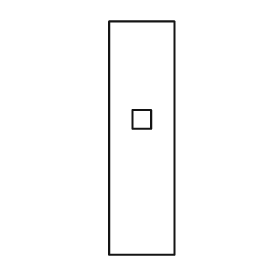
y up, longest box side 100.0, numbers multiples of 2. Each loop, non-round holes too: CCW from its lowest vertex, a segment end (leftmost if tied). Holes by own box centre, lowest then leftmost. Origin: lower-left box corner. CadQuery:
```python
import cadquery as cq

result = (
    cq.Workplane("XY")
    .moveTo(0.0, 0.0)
    .lineTo(28.0, 0.0)
    .lineTo(28.0, 100.0)
    .lineTo(0.0, 100.0)
    .close()
    .moveTo(10.0, 54.0)
    .lineTo(18.0, 54.0)
    .lineTo(18.0, 62.0)
    .lineTo(10.0, 62.0)
    .close()
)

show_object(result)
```